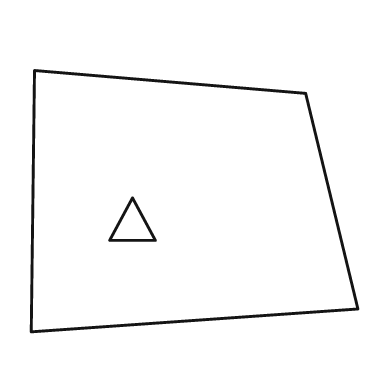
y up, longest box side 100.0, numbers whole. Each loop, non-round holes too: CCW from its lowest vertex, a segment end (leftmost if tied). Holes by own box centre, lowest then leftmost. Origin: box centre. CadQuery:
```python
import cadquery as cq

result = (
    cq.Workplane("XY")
    .moveTo(-50.0, -40.0)
    .lineTo(50.0, -33.0)
    .lineTo(34.0, 33.0)
    .lineTo(-49.0, 40.0)
    .close()
    .moveTo(-26.0, -12.0)
    .lineTo(-12.0, -12.0)
    .lineTo(-19.0, 1.0)
    .close()
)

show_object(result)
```